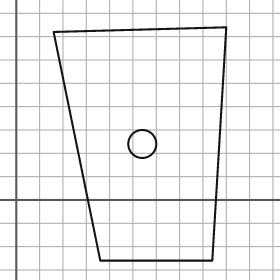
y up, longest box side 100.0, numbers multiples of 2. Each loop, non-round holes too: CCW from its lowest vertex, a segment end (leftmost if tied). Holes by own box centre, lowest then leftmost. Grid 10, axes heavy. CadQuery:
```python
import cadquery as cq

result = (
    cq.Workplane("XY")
    .moveTo(36.0, -26.0)
    .lineTo(84.0, -26.0)
    .lineTo(90.0, 74.0)
    .lineTo(16.0, 72.0)
    .close()
    .moveTo(54.0, 24.0)
    .circle(6.0)
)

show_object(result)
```